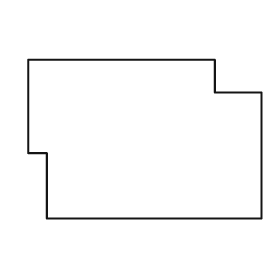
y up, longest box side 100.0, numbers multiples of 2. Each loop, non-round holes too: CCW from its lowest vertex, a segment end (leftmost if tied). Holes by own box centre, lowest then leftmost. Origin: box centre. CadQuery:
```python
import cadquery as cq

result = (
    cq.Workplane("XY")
    .moveTo(-42.0, -34.0)
    .lineTo(50.0, -34.0)
    .lineTo(50.0, 20.0)
    .lineTo(30.0, 20.0)
    .lineTo(30.0, 34.0)
    .lineTo(-50.0, 34.0)
    .lineTo(-50.0, -6.0)
    .lineTo(-42.0, -6.0)
    .close()
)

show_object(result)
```